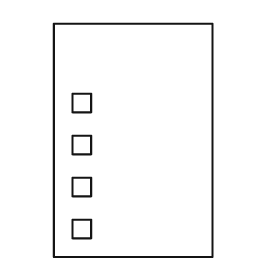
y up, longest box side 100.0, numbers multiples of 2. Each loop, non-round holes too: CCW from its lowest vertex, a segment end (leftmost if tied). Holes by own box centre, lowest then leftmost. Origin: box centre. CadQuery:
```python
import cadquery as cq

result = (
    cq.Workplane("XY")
    .moveTo(-34.0, -50.0)
    .lineTo(34.0, -50.0)
    .lineTo(34.0, 50.0)
    .lineTo(-34.0, 50.0)
    .close()
    .moveTo(-26.0, -42.0)
    .lineTo(-18.0, -42.0)
    .lineTo(-18.0, -34.0)
    .lineTo(-26.0, -34.0)
    .close()
    .moveTo(-26.0, -24.0)
    .lineTo(-18.0, -24.0)
    .lineTo(-18.0, -16.0)
    .lineTo(-26.0, -16.0)
    .close()
    .moveTo(-26.0, -6.0)
    .lineTo(-18.0, -6.0)
    .lineTo(-18.0, 2.0)
    .lineTo(-26.0, 2.0)
    .close()
    .moveTo(-26.0, 12.0)
    .lineTo(-18.0, 12.0)
    .lineTo(-18.0, 20.0)
    .lineTo(-26.0, 20.0)
    .close()
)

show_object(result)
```